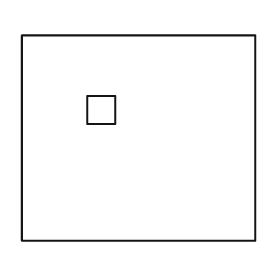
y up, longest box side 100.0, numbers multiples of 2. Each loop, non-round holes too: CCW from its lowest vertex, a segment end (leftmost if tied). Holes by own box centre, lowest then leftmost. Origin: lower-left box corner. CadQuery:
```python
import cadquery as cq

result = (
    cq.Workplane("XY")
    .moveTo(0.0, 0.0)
    .lineTo(100.0, 0.0)
    .lineTo(100.0, 88.0)
    .lineTo(0.0, 88.0)
    .close()
    .moveTo(28.0, 50.0)
    .lineTo(40.0, 50.0)
    .lineTo(40.0, 62.0)
    .lineTo(28.0, 62.0)
    .close()
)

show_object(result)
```